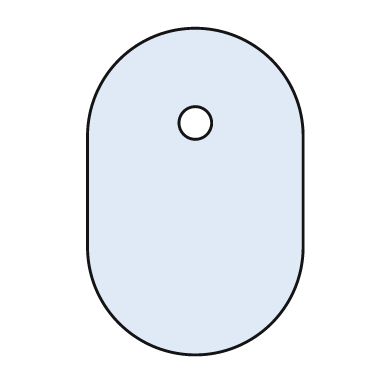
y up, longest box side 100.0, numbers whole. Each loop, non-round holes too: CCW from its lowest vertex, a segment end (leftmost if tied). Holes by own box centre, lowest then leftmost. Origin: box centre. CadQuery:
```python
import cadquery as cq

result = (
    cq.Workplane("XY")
    .moveTo(-33.0, -17.0)
    .threePointArc((0.0, -50.0), (33.0, -17.0))
    .lineTo(33.0, 17.0)
    .threePointArc((0.0, 50.0), (-33.0, 17.0))
    .close()
    .moveTo(0.0, 21.0)
    .circle(5.0)
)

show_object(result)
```